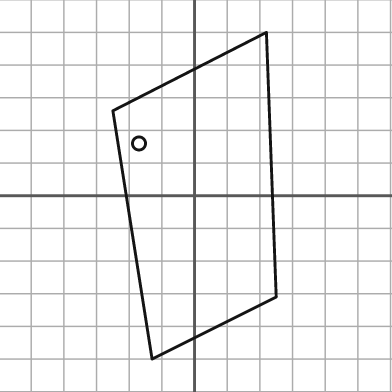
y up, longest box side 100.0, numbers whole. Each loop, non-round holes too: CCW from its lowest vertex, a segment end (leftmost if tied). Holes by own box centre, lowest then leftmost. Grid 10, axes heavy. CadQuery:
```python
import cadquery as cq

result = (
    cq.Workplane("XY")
    .moveTo(-13.0, -50.0)
    .lineTo(25.0, -31.0)
    .lineTo(22.0, 50.0)
    .lineTo(-25.0, 26.0)
    .close()
    .moveTo(-17.0, 16.0)
    .circle(2.0)
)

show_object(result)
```